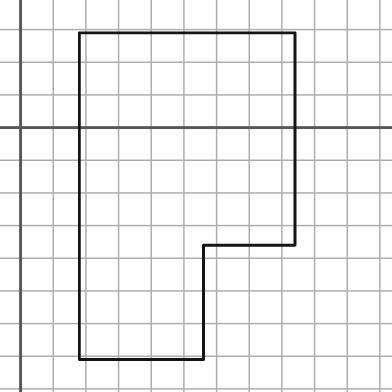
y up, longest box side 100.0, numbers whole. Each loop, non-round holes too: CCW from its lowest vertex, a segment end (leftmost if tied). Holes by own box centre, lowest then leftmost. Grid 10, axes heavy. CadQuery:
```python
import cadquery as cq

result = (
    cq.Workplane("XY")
    .moveTo(18.0, -71.0)
    .lineTo(56.0, -71.0)
    .lineTo(56.0, -36.0)
    .lineTo(84.0, -36.0)
    .lineTo(84.0, 29.0)
    .lineTo(18.0, 29.0)
    .close()
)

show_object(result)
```